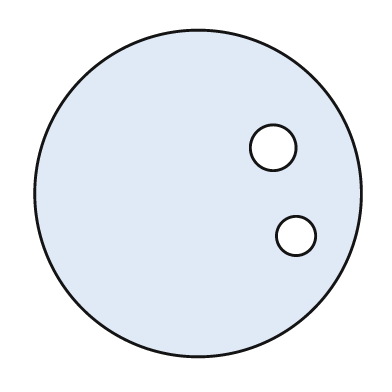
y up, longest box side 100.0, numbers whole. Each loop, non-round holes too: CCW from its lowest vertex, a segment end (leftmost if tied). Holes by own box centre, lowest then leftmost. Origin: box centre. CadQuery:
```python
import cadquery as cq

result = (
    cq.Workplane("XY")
    .moveTo(0.0, 0.0)
    .circle(50.0)
    .moveTo(30.0, -13.0)
    .circle(6.0)
    .moveTo(23.0, 14.0)
    .circle(7.0)
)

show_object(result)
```